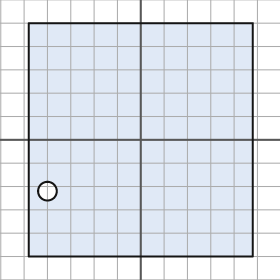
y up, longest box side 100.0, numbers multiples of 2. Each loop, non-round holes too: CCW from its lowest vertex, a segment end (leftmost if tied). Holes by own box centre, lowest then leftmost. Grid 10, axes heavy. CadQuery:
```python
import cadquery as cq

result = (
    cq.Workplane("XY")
    .moveTo(-48.0, -50.0)
    .lineTo(48.0, -50.0)
    .lineTo(48.0, 50.0)
    .lineTo(-48.0, 50.0)
    .close()
    .moveTo(-40.0, -22.0)
    .circle(4.0)
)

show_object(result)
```